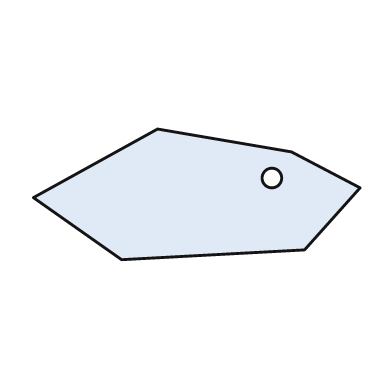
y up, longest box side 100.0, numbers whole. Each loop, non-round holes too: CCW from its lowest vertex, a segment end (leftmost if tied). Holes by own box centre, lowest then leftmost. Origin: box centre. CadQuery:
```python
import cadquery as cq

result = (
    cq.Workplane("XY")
    .moveTo(-23.0, -20.0)
    .lineTo(33.0, -17.0)
    .lineTo(50.0, 2.0)
    .lineTo(29.0, 13.0)
    .lineTo(-12.0, 20.0)
    .lineTo(-50.0, -1.0)
    .close()
    .moveTo(23.0, 5.0)
    .circle(3.0)
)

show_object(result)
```